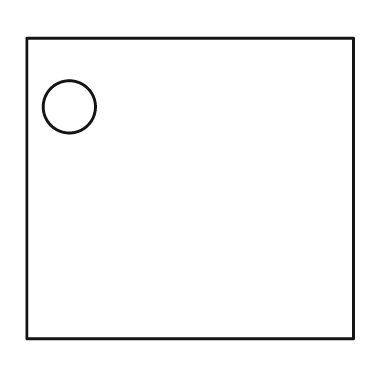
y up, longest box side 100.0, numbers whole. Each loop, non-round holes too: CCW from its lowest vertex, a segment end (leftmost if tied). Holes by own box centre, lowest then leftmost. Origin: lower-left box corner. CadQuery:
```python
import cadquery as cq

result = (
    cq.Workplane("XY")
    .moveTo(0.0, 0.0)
    .lineTo(100.0, 0.0)
    .lineTo(100.0, 92.0)
    .lineTo(0.0, 92.0)
    .close()
    .moveTo(13.0, 71.0)
    .circle(8.0)
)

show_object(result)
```